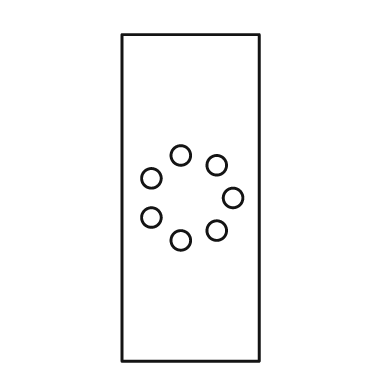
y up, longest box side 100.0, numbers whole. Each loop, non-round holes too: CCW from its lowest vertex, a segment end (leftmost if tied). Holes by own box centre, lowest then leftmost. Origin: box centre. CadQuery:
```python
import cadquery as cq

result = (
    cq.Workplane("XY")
    .moveTo(-21.0, -50.0)
    .lineTo(21.0, -50.0)
    .lineTo(21.0, 50.0)
    .lineTo(-21.0, 50.0)
    .close()
    .moveTo(-3.0, -13.0)
    .circle(3.0)
    .moveTo(8.0, -10.0)
    .circle(3.0)
    .moveTo(-12.0, -6.0)
    .circle(3.0)
    .moveTo(13.0, 0.0)
    .circle(3.0)
    .moveTo(-12.0, 6.0)
    .circle(3.0)
    .moveTo(8.0, 10.0)
    .circle(3.0)
    .moveTo(-3.0, 13.0)
    .circle(3.0)
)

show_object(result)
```